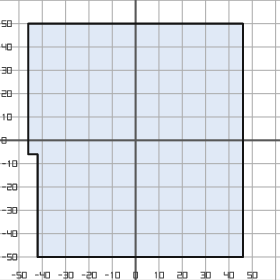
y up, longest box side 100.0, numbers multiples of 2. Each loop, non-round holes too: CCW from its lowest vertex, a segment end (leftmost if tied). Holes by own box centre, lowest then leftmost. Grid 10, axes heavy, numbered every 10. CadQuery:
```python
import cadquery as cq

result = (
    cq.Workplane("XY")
    .moveTo(-42.0, -50.0)
    .lineTo(46.0, -50.0)
    .lineTo(46.0, 50.0)
    .lineTo(-46.0, 50.0)
    .lineTo(-46.0, -6.0)
    .lineTo(-42.0, -6.0)
    .close()
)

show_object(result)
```